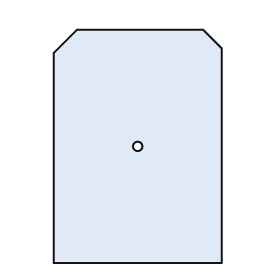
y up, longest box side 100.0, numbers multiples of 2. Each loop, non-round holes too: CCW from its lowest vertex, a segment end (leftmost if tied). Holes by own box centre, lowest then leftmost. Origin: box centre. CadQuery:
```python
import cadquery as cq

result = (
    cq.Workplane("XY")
    .moveTo(-36.0, -50.0)
    .lineTo(36.0, -50.0)
    .lineTo(36.0, 42.0)
    .lineTo(28.0, 50.0)
    .lineTo(-26.0, 50.0)
    .lineTo(-36.0, 40.0)
    .close()
    .moveTo(0.0, 0.0)
    .circle(2.0)
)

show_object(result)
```